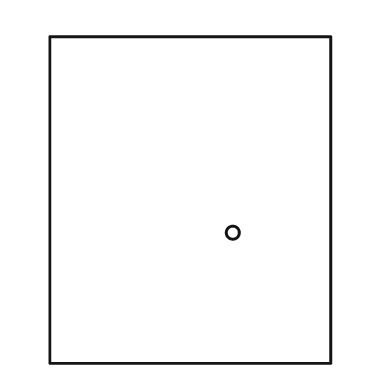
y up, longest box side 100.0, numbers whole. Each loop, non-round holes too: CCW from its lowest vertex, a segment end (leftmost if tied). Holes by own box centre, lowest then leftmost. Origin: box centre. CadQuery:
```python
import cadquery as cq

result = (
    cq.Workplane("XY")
    .moveTo(-43.0, -50.0)
    .lineTo(43.0, -50.0)
    .lineTo(43.0, 50.0)
    .lineTo(-43.0, 50.0)
    .close()
    .moveTo(13.0, -10.0)
    .circle(2.0)
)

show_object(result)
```